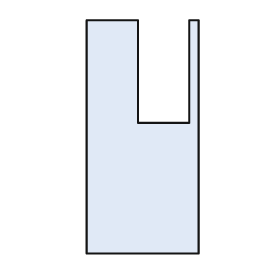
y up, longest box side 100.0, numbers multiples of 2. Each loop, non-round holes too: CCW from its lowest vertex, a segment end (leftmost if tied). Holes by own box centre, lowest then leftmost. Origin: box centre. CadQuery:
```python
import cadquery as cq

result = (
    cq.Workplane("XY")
    .moveTo(-24.0, -50.0)
    .lineTo(24.0, -50.0)
    .lineTo(24.0, 50.0)
    .lineTo(20.0, 50.0)
    .lineTo(20.0, 6.0)
    .lineTo(-2.0, 6.0)
    .lineTo(-2.0, 50.0)
    .lineTo(-24.0, 50.0)
    .close()
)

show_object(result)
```